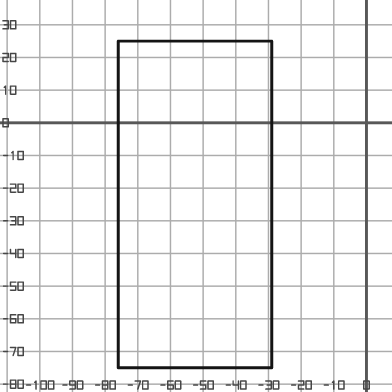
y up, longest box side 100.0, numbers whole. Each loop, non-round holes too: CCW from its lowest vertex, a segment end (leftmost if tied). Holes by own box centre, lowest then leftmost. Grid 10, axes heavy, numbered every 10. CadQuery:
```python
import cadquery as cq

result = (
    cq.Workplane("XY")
    .moveTo(-76.0, -75.0)
    .lineTo(-29.0, -75.0)
    .lineTo(-29.0, 25.0)
    .lineTo(-76.0, 25.0)
    .close()
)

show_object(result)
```